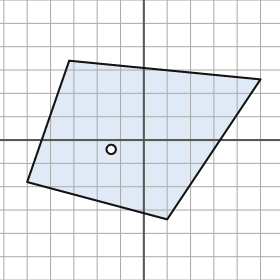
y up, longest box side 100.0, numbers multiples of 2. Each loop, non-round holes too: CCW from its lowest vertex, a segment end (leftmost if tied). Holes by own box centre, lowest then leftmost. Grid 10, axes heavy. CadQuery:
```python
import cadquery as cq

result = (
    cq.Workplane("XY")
    .moveTo(10.0, -34.0)
    .lineTo(50.0, 26.0)
    .lineTo(-32.0, 34.0)
    .lineTo(-50.0, -18.0)
    .close()
    .moveTo(-14.0, -4.0)
    .circle(2.0)
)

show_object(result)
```